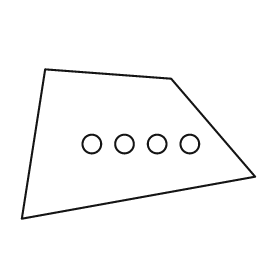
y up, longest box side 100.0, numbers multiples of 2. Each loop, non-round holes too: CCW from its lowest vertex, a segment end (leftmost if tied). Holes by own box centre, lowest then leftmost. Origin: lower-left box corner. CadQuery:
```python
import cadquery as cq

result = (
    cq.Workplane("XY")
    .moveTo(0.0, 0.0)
    .lineTo(100.0, 18.0)
    .lineTo(64.0, 60.0)
    .lineTo(10.0, 64.0)
    .close()
    .moveTo(30.0, 32.0)
    .circle(4.0)
    .moveTo(44.0, 32.0)
    .circle(4.0)
    .moveTo(58.0, 32.0)
    .circle(4.0)
    .moveTo(72.0, 32.0)
    .circle(4.0)
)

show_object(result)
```